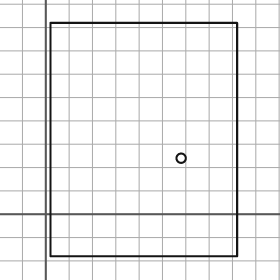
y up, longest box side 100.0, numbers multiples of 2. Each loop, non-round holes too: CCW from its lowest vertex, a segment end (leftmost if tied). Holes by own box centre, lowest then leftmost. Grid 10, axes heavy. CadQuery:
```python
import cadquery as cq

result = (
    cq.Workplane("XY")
    .moveTo(2.0, -18.0)
    .lineTo(82.0, -18.0)
    .lineTo(82.0, 82.0)
    .lineTo(2.0, 82.0)
    .close()
    .moveTo(58.0, 24.0)
    .circle(2.0)
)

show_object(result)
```